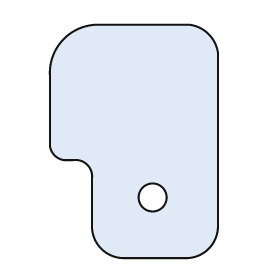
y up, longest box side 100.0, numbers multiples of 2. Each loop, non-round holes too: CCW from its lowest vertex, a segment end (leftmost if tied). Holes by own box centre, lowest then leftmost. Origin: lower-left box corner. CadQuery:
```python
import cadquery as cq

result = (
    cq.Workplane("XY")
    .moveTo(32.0, 0.0)
    .lineTo(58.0, 0.0)
    .threePointArc((68.0, 4.0), (72.0, 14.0))
    .lineTo(72.0, 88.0)
    .threePointArc((68.0, 96.0), (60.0, 100.0))
    .lineTo(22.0, 100.0)
    .threePointArc((6.0, 94.0), (0.0, 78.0))
    .lineTo(0.0, 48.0)
    .threePointArc((2.0, 44.0), (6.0, 42.0))
    .lineTo(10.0, 42.0)
    .threePointArc((16.0, 40.0), (18.0, 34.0))
    .lineTo(18.0, 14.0)
    .threePointArc((22.0, 4.0), (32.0, 0.0))
    .close()
    .moveTo(44.0, 26.0)
    .circle(6.0)
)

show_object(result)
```